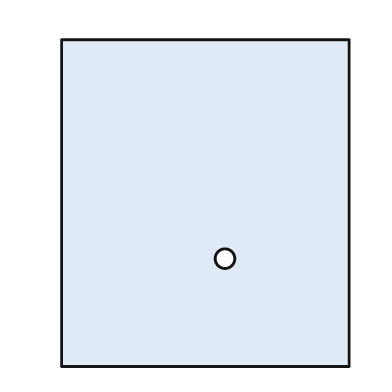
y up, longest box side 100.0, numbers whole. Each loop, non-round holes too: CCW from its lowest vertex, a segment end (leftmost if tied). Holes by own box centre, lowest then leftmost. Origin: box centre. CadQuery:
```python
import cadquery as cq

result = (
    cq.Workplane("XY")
    .moveTo(-44.0, -50.0)
    .lineTo(44.0, -50.0)
    .lineTo(44.0, 50.0)
    .lineTo(-44.0, 50.0)
    .close()
    .moveTo(6.0, -17.0)
    .circle(3.0)
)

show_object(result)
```